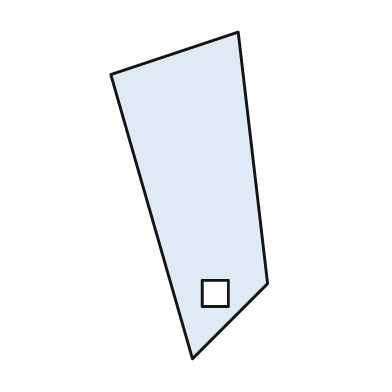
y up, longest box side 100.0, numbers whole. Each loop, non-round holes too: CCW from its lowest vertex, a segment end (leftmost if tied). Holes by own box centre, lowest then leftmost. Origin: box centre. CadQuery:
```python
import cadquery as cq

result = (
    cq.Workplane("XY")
    .moveTo(1.0, -50.0)
    .lineTo(24.0, -27.0)
    .lineTo(15.0, 50.0)
    .lineTo(-24.0, 37.0)
    .close()
    .moveTo(4.0, -34.0)
    .lineTo(12.0, -34.0)
    .lineTo(12.0, -26.0)
    .lineTo(4.0, -26.0)
    .close()
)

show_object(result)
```